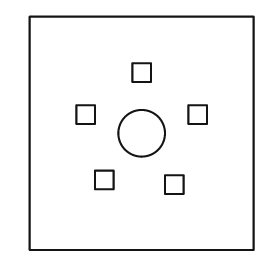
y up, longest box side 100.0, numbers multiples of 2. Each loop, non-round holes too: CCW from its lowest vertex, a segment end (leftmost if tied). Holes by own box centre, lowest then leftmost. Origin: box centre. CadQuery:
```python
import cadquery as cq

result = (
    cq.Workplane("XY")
    .moveTo(-48.0, -50.0)
    .lineTo(48.0, -50.0)
    .lineTo(48.0, 50.0)
    .lineTo(-48.0, 50.0)
    .close()
    .moveTo(10.0, -26.0)
    .lineTo(18.0, -26.0)
    .lineTo(18.0, -18.0)
    .lineTo(10.0, -18.0)
    .close()
    .moveTo(-20.0, -24.0)
    .lineTo(-12.0, -24.0)
    .lineTo(-12.0, -16.0)
    .lineTo(-20.0, -16.0)
    .close()
    .moveTo(0.0, 0.0)
    .circle(10.0)
    .moveTo(-28.0, 4.0)
    .lineTo(-20.0, 4.0)
    .lineTo(-20.0, 12.0)
    .lineTo(-28.0, 12.0)
    .close()
    .moveTo(20.0, 4.0)
    .lineTo(28.0, 4.0)
    .lineTo(28.0, 12.0)
    .lineTo(20.0, 12.0)
    .close()
    .moveTo(-4.0, 22.0)
    .lineTo(4.0, 22.0)
    .lineTo(4.0, 30.0)
    .lineTo(-4.0, 30.0)
    .close()
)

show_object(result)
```